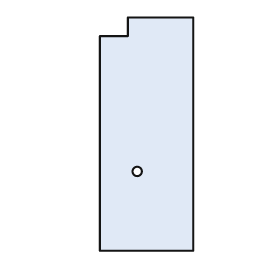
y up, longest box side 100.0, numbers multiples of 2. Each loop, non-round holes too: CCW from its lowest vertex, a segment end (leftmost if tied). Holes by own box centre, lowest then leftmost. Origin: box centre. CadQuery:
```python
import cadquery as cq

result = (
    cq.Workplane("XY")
    .moveTo(-20.0, -50.0)
    .lineTo(20.0, -50.0)
    .lineTo(20.0, 50.0)
    .lineTo(-8.0, 50.0)
    .lineTo(-8.0, 42.0)
    .lineTo(-20.0, 42.0)
    .close()
    .moveTo(-4.0, -16.0)
    .circle(2.0)
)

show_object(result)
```